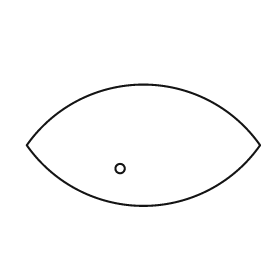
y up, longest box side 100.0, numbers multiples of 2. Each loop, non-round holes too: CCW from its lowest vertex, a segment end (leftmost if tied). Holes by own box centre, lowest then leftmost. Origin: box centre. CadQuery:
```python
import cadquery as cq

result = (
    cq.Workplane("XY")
    .moveTo(-50.0, 0.0)
    .threePointArc((0.0, -26.0), (50.0, 0.0))
    .threePointArc((0.0, 26.0), (-50.0, 0.0))
    .close()
    .moveTo(-10.0, -10.0)
    .circle(2.0)
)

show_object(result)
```